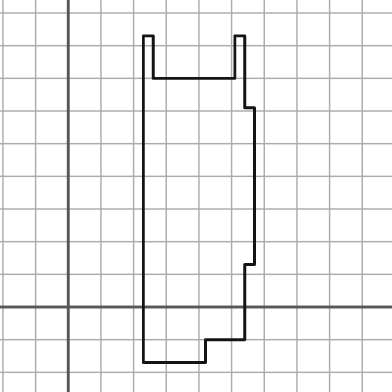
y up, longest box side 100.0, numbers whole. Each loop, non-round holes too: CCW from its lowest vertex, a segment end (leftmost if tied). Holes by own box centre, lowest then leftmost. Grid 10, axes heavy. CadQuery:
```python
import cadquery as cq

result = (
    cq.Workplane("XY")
    .moveTo(23.0, -17.0)
    .lineTo(42.0, -17.0)
    .lineTo(42.0, -10.0)
    .lineTo(54.0, -10.0)
    .lineTo(54.0, 13.0)
    .lineTo(57.0, 13.0)
    .lineTo(57.0, 61.0)
    .lineTo(54.0, 61.0)
    .lineTo(54.0, 83.0)
    .lineTo(51.0, 83.0)
    .lineTo(51.0, 70.0)
    .lineTo(26.0, 70.0)
    .lineTo(26.0, 83.0)
    .lineTo(23.0, 83.0)
    .close()
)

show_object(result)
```